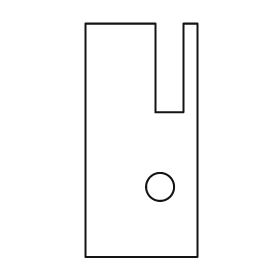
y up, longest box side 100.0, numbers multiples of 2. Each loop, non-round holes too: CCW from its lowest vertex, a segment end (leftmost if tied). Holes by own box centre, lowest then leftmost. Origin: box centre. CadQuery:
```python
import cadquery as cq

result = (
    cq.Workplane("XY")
    .moveTo(-24.0, -50.0)
    .lineTo(24.0, -50.0)
    .lineTo(24.0, 50.0)
    .lineTo(18.0, 50.0)
    .lineTo(18.0, 12.0)
    .lineTo(6.0, 12.0)
    .lineTo(6.0, 50.0)
    .lineTo(-24.0, 50.0)
    .close()
    .moveTo(8.0, -20.0)
    .circle(6.0)
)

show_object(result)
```